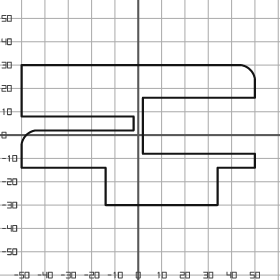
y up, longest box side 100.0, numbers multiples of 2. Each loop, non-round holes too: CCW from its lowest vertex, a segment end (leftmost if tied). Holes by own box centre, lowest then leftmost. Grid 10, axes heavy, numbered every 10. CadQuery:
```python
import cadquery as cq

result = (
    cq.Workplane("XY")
    .moveTo(-14.0, -30.0)
    .lineTo(34.0, -30.0)
    .lineTo(34.0, -14.0)
    .lineTo(50.0, -14.0)
    .lineTo(50.0, -8.0)
    .lineTo(2.0, -8.0)
    .lineTo(2.0, 16.0)
    .lineTo(50.0, 16.0)
    .lineTo(50.0, 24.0)
    .threePointArc((48.0, 28.0), (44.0, 30.0))
    .lineTo(-50.0, 30.0)
    .lineTo(-50.0, 8.0)
    .lineTo(-2.0, 8.0)
    .lineTo(-2.0, 2.0)
    .lineTo(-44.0, 2.0)
    .threePointArc((-48.0, 0.0), (-50.0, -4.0))
    .lineTo(-50.0, -14.0)
    .lineTo(-14.0, -14.0)
    .close()
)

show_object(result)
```